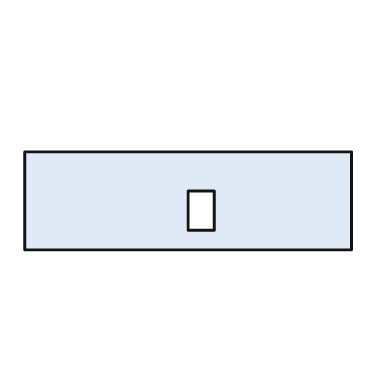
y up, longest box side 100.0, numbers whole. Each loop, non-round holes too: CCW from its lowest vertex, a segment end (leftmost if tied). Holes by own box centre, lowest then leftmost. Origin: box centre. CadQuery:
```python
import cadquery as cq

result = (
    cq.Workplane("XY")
    .moveTo(-50.0, -15.0)
    .lineTo(50.0, -15.0)
    .lineTo(50.0, 15.0)
    .lineTo(-50.0, 15.0)
    .close()
    .moveTo(0.0, -9.0)
    .lineTo(8.0, -9.0)
    .lineTo(8.0, 3.0)
    .lineTo(0.0, 3.0)
    .close()
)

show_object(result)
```